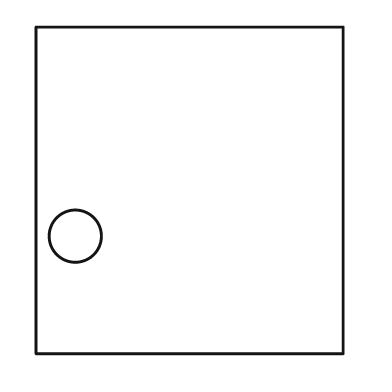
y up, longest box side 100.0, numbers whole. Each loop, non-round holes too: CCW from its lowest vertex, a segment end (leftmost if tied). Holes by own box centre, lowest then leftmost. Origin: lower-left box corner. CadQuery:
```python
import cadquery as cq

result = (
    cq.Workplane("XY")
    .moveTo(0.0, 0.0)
    .lineTo(94.0, 0.0)
    .lineTo(94.0, 100.0)
    .lineTo(0.0, 100.0)
    .close()
    .moveTo(12.0, 36.0)
    .circle(8.0)
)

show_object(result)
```